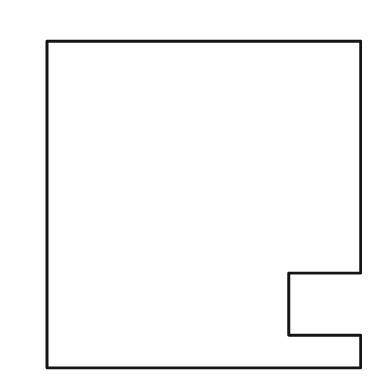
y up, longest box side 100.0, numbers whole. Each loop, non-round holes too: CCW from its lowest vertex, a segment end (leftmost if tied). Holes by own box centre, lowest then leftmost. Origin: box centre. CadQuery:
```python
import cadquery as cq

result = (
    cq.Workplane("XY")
    .moveTo(-48.0, -50.0)
    .lineTo(48.0, -50.0)
    .lineTo(48.0, -40.0)
    .lineTo(26.0, -40.0)
    .lineTo(26.0, -21.0)
    .lineTo(48.0, -21.0)
    .lineTo(48.0, 50.0)
    .lineTo(-48.0, 50.0)
    .close()
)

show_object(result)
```